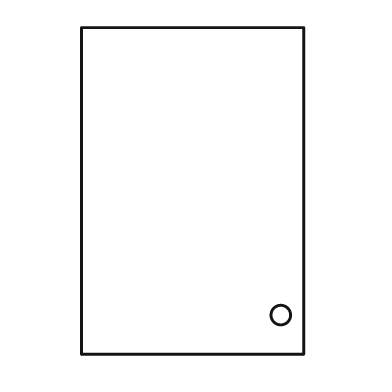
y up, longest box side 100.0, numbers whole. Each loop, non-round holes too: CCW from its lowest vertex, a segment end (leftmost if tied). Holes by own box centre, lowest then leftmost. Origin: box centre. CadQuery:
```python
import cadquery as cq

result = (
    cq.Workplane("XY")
    .moveTo(-34.0, -50.0)
    .lineTo(34.0, -50.0)
    .lineTo(34.0, 50.0)
    .lineTo(-34.0, 50.0)
    .close()
    .moveTo(27.0, -38.0)
    .circle(3.0)
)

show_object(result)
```